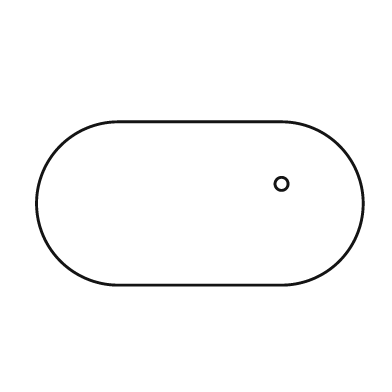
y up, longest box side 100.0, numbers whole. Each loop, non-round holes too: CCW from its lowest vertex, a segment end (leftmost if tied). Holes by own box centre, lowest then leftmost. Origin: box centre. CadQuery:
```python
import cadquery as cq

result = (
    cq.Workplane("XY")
    .moveTo(-25.0, -25.0)
    .lineTo(25.0, -25.0)
    .threePointArc((50.0, 0.0), (25.0, 25.0))
    .lineTo(-25.0, 25.0)
    .threePointArc((-50.0, 0.0), (-25.0, -25.0))
    .close()
    .moveTo(25.0, 6.0)
    .circle(2.0)
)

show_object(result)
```